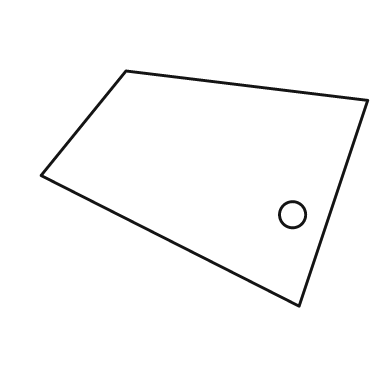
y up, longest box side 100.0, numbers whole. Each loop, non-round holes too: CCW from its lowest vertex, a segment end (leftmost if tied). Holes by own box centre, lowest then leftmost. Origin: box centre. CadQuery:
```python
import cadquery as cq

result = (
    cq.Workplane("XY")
    .moveTo(29.0, -36.0)
    .lineTo(50.0, 27.0)
    .lineTo(-24.0, 36.0)
    .lineTo(-50.0, 4.0)
    .close()
    .moveTo(27.0, -8.0)
    .circle(4.0)
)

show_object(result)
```